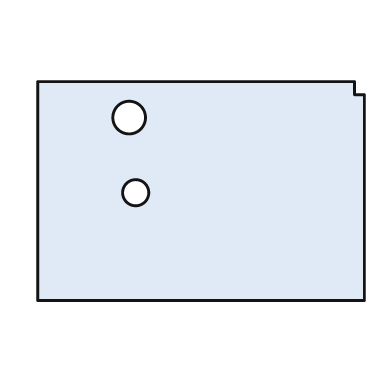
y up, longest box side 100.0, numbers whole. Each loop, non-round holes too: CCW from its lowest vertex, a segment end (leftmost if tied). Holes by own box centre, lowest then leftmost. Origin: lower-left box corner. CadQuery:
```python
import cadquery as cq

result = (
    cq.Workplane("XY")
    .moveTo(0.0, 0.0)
    .lineTo(100.0, 0.0)
    .lineTo(100.0, 63.0)
    .lineTo(97.0, 63.0)
    .lineTo(97.0, 67.0)
    .lineTo(0.0, 67.0)
    .close()
    .moveTo(30.0, 33.0)
    .circle(4.0)
    .moveTo(28.0, 56.0)
    .circle(5.0)
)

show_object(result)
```